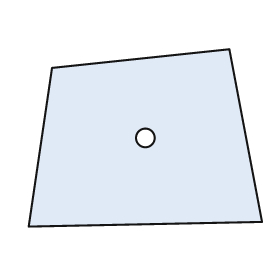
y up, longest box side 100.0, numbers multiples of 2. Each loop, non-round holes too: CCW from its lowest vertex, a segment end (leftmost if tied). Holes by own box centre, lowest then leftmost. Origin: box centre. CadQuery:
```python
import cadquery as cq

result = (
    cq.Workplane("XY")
    .moveTo(-50.0, -38.0)
    .lineTo(50.0, -36.0)
    .lineTo(36.0, 38.0)
    .lineTo(-40.0, 30.0)
    .close()
    .moveTo(0.0, 0.0)
    .circle(4.0)
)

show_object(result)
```